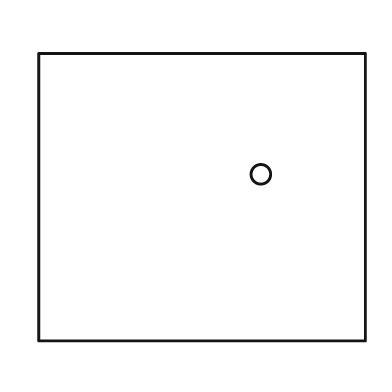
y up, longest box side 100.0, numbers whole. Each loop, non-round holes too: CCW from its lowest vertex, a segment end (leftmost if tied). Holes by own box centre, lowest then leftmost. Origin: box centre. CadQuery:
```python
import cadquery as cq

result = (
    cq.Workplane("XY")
    .moveTo(-50.0, -44.0)
    .lineTo(50.0, -44.0)
    .lineTo(50.0, 44.0)
    .lineTo(-50.0, 44.0)
    .close()
    .moveTo(18.0, 7.0)
    .circle(3.0)
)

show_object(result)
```